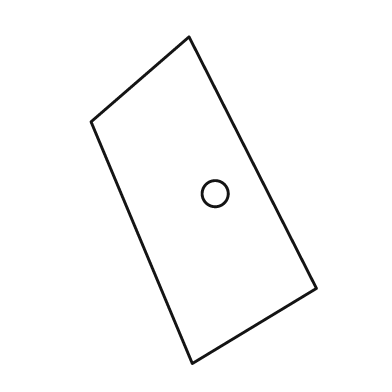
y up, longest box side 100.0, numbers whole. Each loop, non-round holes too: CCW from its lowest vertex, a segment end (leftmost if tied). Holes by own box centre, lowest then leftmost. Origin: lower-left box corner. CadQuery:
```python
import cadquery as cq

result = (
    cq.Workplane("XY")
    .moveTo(31.0, 0.0)
    .lineTo(69.0, 23.0)
    .lineTo(30.0, 100.0)
    .lineTo(0.0, 74.0)
    .close()
    .moveTo(38.0, 52.0)
    .circle(4.0)
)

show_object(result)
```